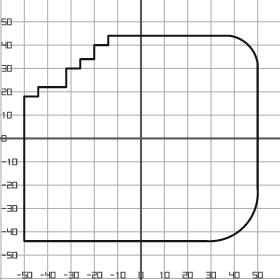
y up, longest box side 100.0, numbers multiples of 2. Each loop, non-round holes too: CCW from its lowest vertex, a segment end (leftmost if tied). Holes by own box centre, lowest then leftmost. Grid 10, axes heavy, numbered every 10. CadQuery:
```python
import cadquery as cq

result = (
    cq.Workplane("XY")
    .moveTo(-50.0, -44.0)
    .lineTo(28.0, -44.0)
    .threePointArc((44.0, -38.0), (50.0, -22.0))
    .lineTo(50.0, 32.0)
    .threePointArc((46.0, 40.0), (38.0, 44.0))
    .lineTo(-14.0, 44.0)
    .lineTo(-14.0, 40.0)
    .lineTo(-20.0, 40.0)
    .lineTo(-20.0, 34.0)
    .lineTo(-26.0, 34.0)
    .lineTo(-26.0, 30.0)
    .lineTo(-32.0, 30.0)
    .lineTo(-32.0, 22.0)
    .lineTo(-44.0, 22.0)
    .lineTo(-44.0, 18.0)
    .lineTo(-50.0, 18.0)
    .close()
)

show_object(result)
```